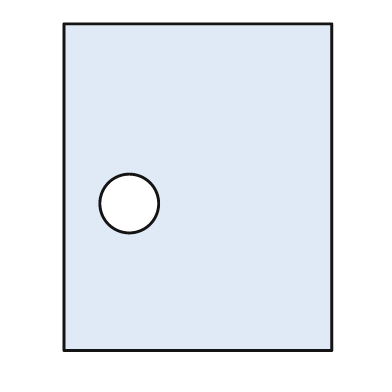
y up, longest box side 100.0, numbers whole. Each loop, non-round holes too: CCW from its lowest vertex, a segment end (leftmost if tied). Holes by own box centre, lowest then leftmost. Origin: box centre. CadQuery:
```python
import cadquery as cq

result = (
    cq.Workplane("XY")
    .moveTo(-41.0, -50.0)
    .lineTo(41.0, -50.0)
    .lineTo(41.0, 50.0)
    .lineTo(-41.0, 50.0)
    .close()
    .moveTo(-21.0, -5.0)
    .circle(9.0)
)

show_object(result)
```